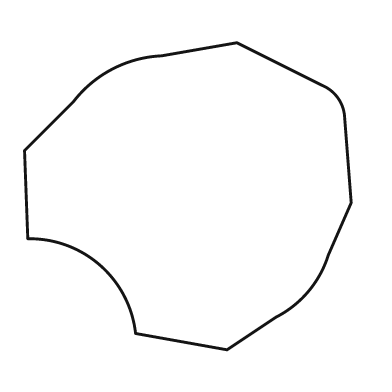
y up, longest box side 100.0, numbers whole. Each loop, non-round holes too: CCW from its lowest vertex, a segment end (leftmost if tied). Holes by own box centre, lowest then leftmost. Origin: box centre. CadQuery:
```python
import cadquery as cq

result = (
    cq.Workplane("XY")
    .moveTo(12.0, -47.0)
    .lineTo(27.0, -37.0)
    .threePointArc((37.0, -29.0), (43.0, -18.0))
    .lineTo(50.0, -2.0)
    .lineTo(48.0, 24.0)
    .threePointArc((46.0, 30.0), (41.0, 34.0))
    .lineTo(15.0, 47.0)
    .lineTo(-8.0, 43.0)
    .threePointArc((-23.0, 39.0), (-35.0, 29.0))
    .lineTo(-50.0, 14.0)
    .lineTo(-49.0, -13.0)
    .threePointArc((-27.0, -21.0), (-16.0, -42.0))
    .close()
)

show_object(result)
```